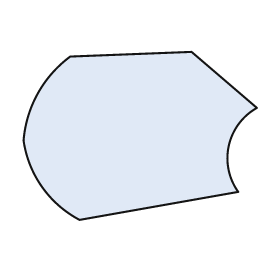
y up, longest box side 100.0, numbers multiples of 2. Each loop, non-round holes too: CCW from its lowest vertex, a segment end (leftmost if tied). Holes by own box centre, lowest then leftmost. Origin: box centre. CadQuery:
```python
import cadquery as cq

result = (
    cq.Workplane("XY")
    .moveTo(-26.0, -36.0)
    .lineTo(42.0, -24.0)
    .threePointArc((38.0, -4.0), (50.0, 12.0))
    .lineTo(22.0, 36.0)
    .lineTo(-30.0, 34.0)
    .threePointArc((-44.0, 18.0), (-50.0, -2.0))
    .threePointArc((-42.0, -22.0), (-26.0, -36.0))
    .close()
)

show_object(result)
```